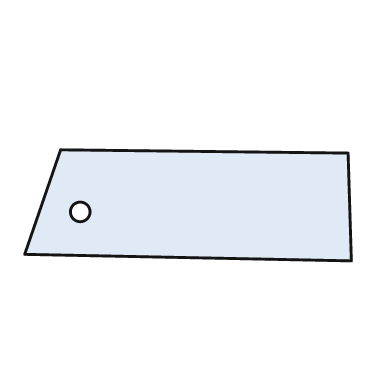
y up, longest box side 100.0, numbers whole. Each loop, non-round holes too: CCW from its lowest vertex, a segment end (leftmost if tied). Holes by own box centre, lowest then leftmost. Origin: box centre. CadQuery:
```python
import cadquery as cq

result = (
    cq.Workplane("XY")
    .moveTo(50.0, -17.0)
    .lineTo(49.0, 16.0)
    .lineTo(-39.0, 17.0)
    .lineTo(-50.0, -15.0)
    .close()
    .moveTo(-33.0, -2.0)
    .circle(3.0)
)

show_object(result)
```